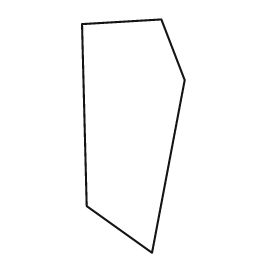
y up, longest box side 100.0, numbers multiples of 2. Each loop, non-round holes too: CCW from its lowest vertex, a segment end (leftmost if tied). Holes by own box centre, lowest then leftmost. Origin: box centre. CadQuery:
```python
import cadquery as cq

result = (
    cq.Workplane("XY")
    .moveTo(8.0, -50.0)
    .lineTo(22.0, 24.0)
    .lineTo(12.0, 50.0)
    .lineTo(-22.0, 48.0)
    .lineTo(-20.0, -30.0)
    .close()
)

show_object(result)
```